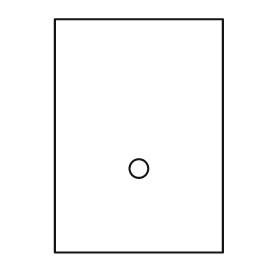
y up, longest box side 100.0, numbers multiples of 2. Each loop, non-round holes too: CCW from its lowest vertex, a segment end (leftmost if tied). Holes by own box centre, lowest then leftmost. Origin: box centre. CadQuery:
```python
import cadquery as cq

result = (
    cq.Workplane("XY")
    .moveTo(-36.0, -50.0)
    .lineTo(36.0, -50.0)
    .lineTo(36.0, 50.0)
    .lineTo(-36.0, 50.0)
    .close()
    .moveTo(0.0, -14.0)
    .circle(4.0)
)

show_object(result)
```